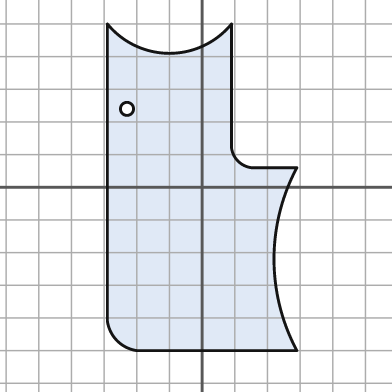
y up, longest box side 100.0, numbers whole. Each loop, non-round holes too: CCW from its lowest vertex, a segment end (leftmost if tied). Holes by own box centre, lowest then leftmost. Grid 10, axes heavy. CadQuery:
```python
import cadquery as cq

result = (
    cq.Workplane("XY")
    .moveTo(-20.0, -50.0)
    .lineTo(29.0, -50.0)
    .threePointArc((22.0, -22.0), (29.0, 6.0))
    .lineTo(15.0, 6.0)
    .threePointArc((11.0, 8.0), (9.0, 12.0))
    .lineTo(9.0, 50.0)
    .threePointArc((-10.0, 41.0), (-29.0, 50.0))
    .lineTo(-29.0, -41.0)
    .threePointArc((-26.0, -47.0), (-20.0, -50.0))
    .close()
    .moveTo(-23.0, 24.0)
    .circle(2.0)
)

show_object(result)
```